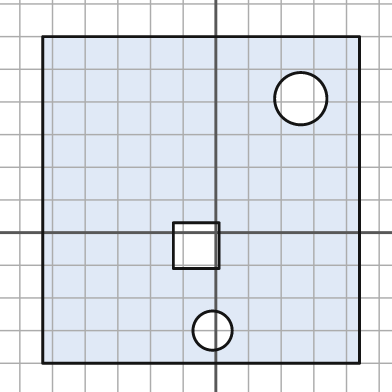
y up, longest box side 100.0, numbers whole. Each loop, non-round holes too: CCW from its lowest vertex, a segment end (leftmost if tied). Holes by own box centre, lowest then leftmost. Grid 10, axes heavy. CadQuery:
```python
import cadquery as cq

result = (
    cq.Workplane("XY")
    .moveTo(-53.0, -40.0)
    .lineTo(44.0, -40.0)
    .lineTo(44.0, 60.0)
    .lineTo(-53.0, 60.0)
    .close()
    .moveTo(-1.0, -30.0)
    .circle(6.0)
    .moveTo(-13.0, -11.0)
    .lineTo(1.0, -11.0)
    .lineTo(1.0, 3.0)
    .lineTo(-13.0, 3.0)
    .close()
    .moveTo(26.0, 41.0)
    .circle(8.0)
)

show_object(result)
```